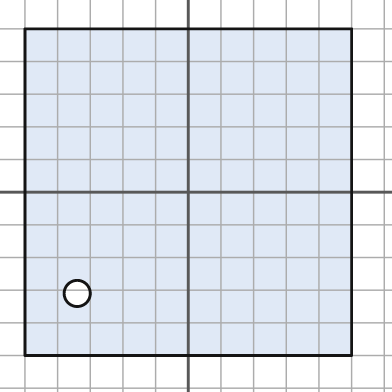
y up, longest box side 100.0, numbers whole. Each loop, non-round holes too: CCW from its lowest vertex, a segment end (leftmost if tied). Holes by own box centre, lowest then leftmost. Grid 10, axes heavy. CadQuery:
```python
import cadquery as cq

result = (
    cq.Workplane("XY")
    .moveTo(-50.0, -50.0)
    .lineTo(50.0, -50.0)
    .lineTo(50.0, 50.0)
    .lineTo(-50.0, 50.0)
    .close()
    .moveTo(-34.0, -31.0)
    .circle(4.0)
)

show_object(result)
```